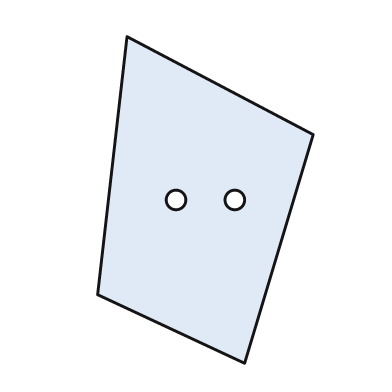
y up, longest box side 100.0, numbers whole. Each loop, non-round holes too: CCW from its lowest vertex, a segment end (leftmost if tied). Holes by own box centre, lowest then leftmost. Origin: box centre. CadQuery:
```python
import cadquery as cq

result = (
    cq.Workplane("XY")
    .moveTo(12.0, -50.0)
    .lineTo(33.0, 20.0)
    .lineTo(-24.0, 50.0)
    .lineTo(-33.0, -29.0)
    .close()
    .moveTo(-9.0, 0.0)
    .circle(3.0)
    .moveTo(9.0, 0.0)
    .circle(3.0)
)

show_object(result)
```